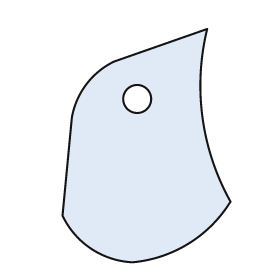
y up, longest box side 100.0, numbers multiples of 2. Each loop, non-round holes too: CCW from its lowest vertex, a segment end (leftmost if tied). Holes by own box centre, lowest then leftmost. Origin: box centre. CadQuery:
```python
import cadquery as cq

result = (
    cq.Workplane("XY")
    .moveTo(-6.0, -50.0)
    .threePointArc((18.0, -42.0), (36.0, -24.0))
    .threePointArc((24.0, 12.0), (26.0, 50.0))
    .lineTo(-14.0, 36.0)
    .threePointArc((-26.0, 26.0), (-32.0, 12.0))
    .lineTo(-36.0, -30.0)
    .threePointArc((-24.0, -44.0), (-6.0, -50.0))
    .close()
    .moveTo(-4.0, 20.0)
    .circle(6.0)
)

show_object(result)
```